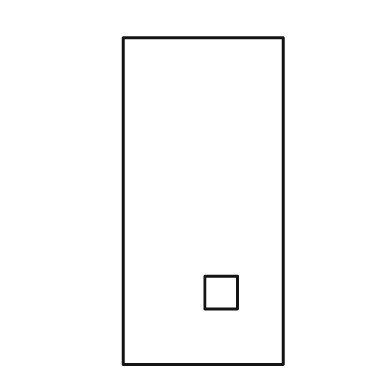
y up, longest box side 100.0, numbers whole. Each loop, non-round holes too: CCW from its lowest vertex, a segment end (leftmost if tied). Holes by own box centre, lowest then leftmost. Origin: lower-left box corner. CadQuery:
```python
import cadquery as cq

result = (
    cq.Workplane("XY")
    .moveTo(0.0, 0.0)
    .lineTo(49.0, 0.0)
    .lineTo(49.0, 100.0)
    .lineTo(0.0, 100.0)
    .close()
    .moveTo(25.0, 17.0)
    .lineTo(35.0, 17.0)
    .lineTo(35.0, 27.0)
    .lineTo(25.0, 27.0)
    .close()
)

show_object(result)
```